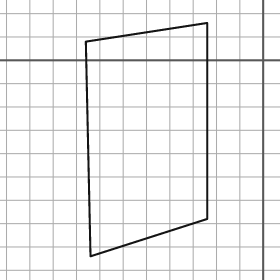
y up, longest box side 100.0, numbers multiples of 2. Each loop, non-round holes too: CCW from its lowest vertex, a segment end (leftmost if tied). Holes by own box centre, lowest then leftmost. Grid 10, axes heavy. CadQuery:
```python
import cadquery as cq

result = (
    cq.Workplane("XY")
    .moveTo(-74.0, -84.0)
    .lineTo(-24.0, -68.0)
    .lineTo(-24.0, 16.0)
    .lineTo(-76.0, 8.0)
    .close()
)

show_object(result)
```